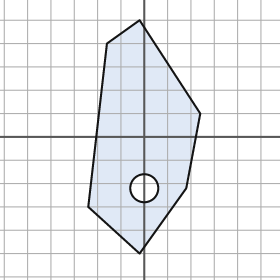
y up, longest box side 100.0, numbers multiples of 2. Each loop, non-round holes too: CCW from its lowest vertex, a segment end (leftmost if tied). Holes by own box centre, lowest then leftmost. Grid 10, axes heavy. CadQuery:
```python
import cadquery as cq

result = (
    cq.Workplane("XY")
    .moveTo(-2.0, -50.0)
    .lineTo(18.0, -22.0)
    .lineTo(24.0, 10.0)
    .lineTo(-2.0, 50.0)
    .lineTo(-16.0, 40.0)
    .lineTo(-24.0, -30.0)
    .close()
    .moveTo(0.0, -22.0)
    .circle(6.0)
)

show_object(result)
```